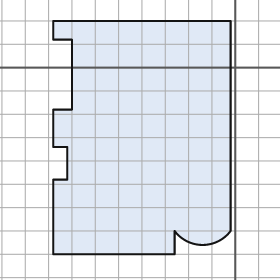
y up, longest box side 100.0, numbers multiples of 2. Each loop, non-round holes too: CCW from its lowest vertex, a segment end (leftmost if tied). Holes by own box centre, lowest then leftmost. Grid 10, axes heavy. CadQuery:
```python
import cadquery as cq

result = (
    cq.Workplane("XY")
    .moveTo(-78.0, -80.0)
    .lineTo(-26.0, -80.0)
    .lineTo(-26.0, -70.0)
    .threePointArc((-14.0, -76.0), (-2.0, -70.0))
    .lineTo(-2.0, 20.0)
    .lineTo(-78.0, 20.0)
    .lineTo(-78.0, 12.0)
    .lineTo(-70.0, 12.0)
    .lineTo(-70.0, -18.0)
    .lineTo(-78.0, -18.0)
    .lineTo(-78.0, -34.0)
    .lineTo(-72.0, -34.0)
    .lineTo(-72.0, -48.0)
    .lineTo(-78.0, -48.0)
    .close()
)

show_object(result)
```